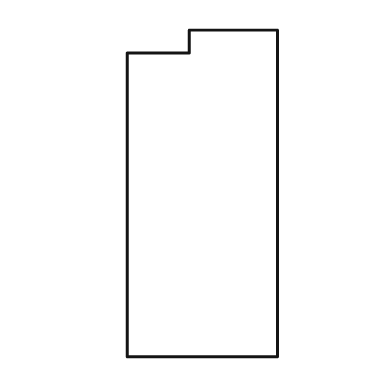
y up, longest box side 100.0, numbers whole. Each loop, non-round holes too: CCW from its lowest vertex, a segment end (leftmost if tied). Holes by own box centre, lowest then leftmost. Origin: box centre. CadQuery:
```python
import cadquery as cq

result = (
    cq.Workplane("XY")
    .moveTo(-23.0, -50.0)
    .lineTo(23.0, -50.0)
    .lineTo(23.0, 50.0)
    .lineTo(-4.0, 50.0)
    .lineTo(-4.0, 43.0)
    .lineTo(-23.0, 43.0)
    .close()
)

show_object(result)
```